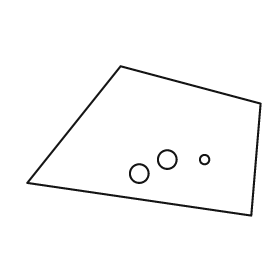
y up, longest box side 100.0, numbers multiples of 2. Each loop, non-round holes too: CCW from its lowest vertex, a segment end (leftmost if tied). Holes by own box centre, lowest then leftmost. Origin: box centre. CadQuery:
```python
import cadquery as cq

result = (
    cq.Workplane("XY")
    .moveTo(46.0, -32.0)
    .lineTo(50.0, 16.0)
    .lineTo(-10.0, 32.0)
    .lineTo(-50.0, -18.0)
    .close()
    .moveTo(-2.0, -14.0)
    .circle(4.0)
    .moveTo(10.0, -8.0)
    .circle(4.0)
    .moveTo(26.0, -8.0)
    .circle(2.0)
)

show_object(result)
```